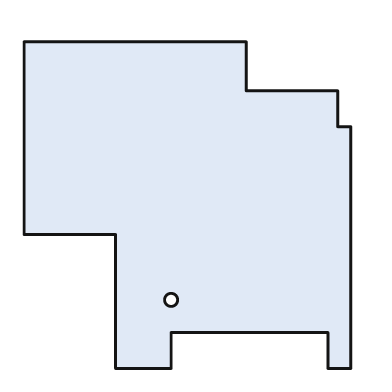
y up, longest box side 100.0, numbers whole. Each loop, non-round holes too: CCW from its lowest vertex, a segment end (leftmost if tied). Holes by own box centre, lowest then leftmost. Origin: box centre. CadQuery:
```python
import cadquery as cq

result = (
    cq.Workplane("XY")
    .moveTo(-22.0, -50.0)
    .lineTo(-5.0, -50.0)
    .lineTo(-5.0, -39.0)
    .lineTo(43.0, -39.0)
    .lineTo(43.0, -50.0)
    .lineTo(50.0, -50.0)
    .lineTo(50.0, 24.0)
    .lineTo(46.0, 24.0)
    .lineTo(46.0, 35.0)
    .lineTo(18.0, 35.0)
    .lineTo(18.0, 50.0)
    .lineTo(-50.0, 50.0)
    .lineTo(-50.0, -9.0)
    .lineTo(-22.0, -9.0)
    .close()
    .moveTo(-5.0, -29.0)
    .circle(2.0)
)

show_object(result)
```